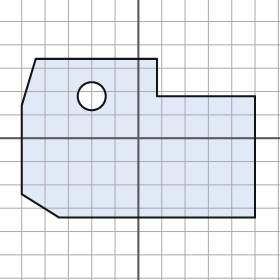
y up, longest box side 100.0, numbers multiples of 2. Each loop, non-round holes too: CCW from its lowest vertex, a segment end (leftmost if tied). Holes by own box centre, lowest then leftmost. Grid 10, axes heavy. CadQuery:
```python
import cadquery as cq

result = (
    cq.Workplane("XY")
    .moveTo(-34.0, -34.0)
    .lineTo(50.0, -34.0)
    .lineTo(50.0, 18.0)
    .lineTo(8.0, 18.0)
    .lineTo(8.0, 34.0)
    .lineTo(-44.0, 34.0)
    .lineTo(-50.0, 14.0)
    .lineTo(-50.0, -24.0)
    .close()
    .moveTo(-20.0, 18.0)
    .circle(6.0)
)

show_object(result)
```